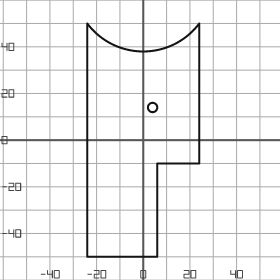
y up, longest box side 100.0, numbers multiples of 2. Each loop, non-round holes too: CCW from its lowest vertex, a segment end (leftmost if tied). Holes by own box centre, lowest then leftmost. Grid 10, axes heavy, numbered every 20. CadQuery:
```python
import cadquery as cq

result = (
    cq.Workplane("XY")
    .moveTo(-24.0, -50.0)
    .lineTo(6.0, -50.0)
    .lineTo(6.0, -10.0)
    .lineTo(24.0, -10.0)
    .lineTo(24.0, 50.0)
    .threePointArc((0.0, 38.0), (-24.0, 50.0))
    .close()
    .moveTo(4.0, 14.0)
    .circle(2.0)
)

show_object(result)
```